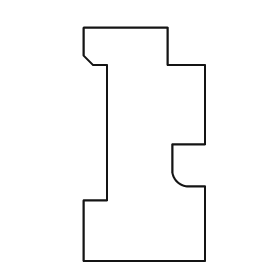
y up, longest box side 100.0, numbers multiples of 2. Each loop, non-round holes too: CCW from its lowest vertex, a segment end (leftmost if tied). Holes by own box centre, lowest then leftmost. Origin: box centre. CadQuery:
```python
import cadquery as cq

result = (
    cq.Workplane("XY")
    .moveTo(-26.0, -50.0)
    .lineTo(26.0, -50.0)
    .lineTo(26.0, -18.0)
    .lineTo(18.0, -18.0)
    .threePointArc((14.0, -16.0), (12.0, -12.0))
    .lineTo(12.0, 0.0)
    .lineTo(26.0, 0.0)
    .lineTo(26.0, 34.0)
    .lineTo(10.0, 34.0)
    .lineTo(10.0, 50.0)
    .lineTo(-26.0, 50.0)
    .lineTo(-26.0, 38.0)
    .lineTo(-22.0, 34.0)
    .lineTo(-16.0, 34.0)
    .lineTo(-16.0, -24.0)
    .lineTo(-26.0, -24.0)
    .close()
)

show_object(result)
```